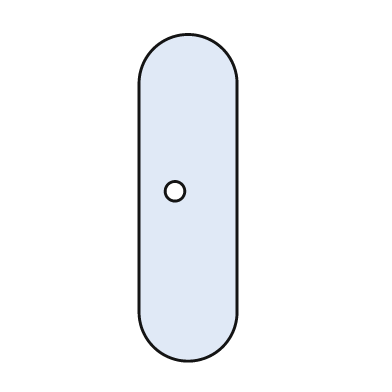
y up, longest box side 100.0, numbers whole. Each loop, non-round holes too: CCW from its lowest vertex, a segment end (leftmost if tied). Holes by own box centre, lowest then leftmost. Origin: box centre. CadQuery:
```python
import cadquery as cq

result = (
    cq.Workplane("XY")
    .moveTo(-15.0, -35.0)
    .threePointArc((0.0, -50.0), (15.0, -35.0))
    .lineTo(15.0, 35.0)
    .threePointArc((0.0, 50.0), (-15.0, 35.0))
    .close()
    .moveTo(-4.0, 2.0)
    .circle(3.0)
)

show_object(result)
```